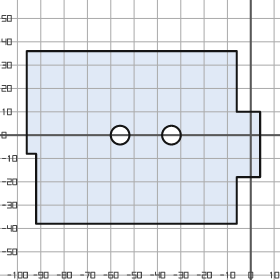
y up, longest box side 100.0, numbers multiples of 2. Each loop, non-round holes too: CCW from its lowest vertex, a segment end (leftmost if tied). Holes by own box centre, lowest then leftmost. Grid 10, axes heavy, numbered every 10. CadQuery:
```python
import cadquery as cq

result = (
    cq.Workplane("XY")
    .moveTo(-92.0, -38.0)
    .lineTo(-6.0, -38.0)
    .lineTo(-6.0, -18.0)
    .lineTo(4.0, -18.0)
    .lineTo(4.0, 10.0)
    .lineTo(-6.0, 10.0)
    .lineTo(-6.0, 36.0)
    .lineTo(-96.0, 36.0)
    .lineTo(-96.0, -8.0)
    .lineTo(-92.0, -8.0)
    .close()
    .moveTo(-56.0, 0.0)
    .circle(4.0)
    .moveTo(-34.0, 0.0)
    .circle(4.0)
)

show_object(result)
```